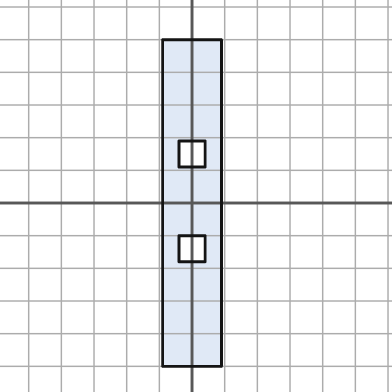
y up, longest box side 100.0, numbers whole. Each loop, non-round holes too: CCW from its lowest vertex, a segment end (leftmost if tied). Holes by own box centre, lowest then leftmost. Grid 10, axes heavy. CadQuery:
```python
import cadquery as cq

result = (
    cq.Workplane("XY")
    .moveTo(-9.0, -50.0)
    .lineTo(9.0, -50.0)
    .lineTo(9.0, 50.0)
    .lineTo(-9.0, 50.0)
    .close()
    .moveTo(-4.0, -18.0)
    .lineTo(4.0, -18.0)
    .lineTo(4.0, -10.0)
    .lineTo(-4.0, -10.0)
    .close()
    .moveTo(-4.0, 11.0)
    .lineTo(4.0, 11.0)
    .lineTo(4.0, 19.0)
    .lineTo(-4.0, 19.0)
    .close()
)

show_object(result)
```